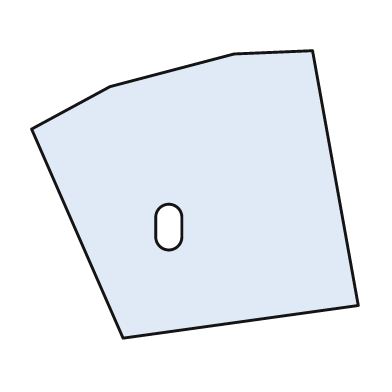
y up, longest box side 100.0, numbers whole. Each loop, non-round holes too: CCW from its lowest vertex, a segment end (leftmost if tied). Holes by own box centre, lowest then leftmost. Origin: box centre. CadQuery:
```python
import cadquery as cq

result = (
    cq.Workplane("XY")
    .moveTo(-22.0, -44.0)
    .lineTo(50.0, -34.0)
    .lineTo(36.0, 44.0)
    .lineTo(12.0, 43.0)
    .lineTo(-26.0, 33.0)
    .lineTo(-50.0, 20.0)
    .close()
    .moveTo(-12.0, -13.0)
    .threePointArc((-8.0, -17.0), (-4.0, -13.0))
    .lineTo(-4.0, -7.0)
    .threePointArc((-8.0, -3.0), (-12.0, -7.0))
    .close()
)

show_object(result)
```